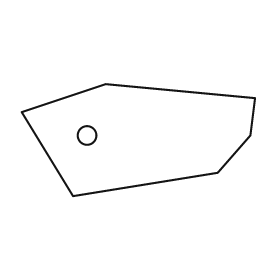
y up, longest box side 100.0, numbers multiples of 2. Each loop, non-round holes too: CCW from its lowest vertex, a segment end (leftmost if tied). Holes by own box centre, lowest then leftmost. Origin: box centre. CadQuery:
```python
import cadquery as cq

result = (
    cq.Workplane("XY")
    .moveTo(-28.0, -24.0)
    .lineTo(34.0, -14.0)
    .lineTo(48.0, 2.0)
    .lineTo(50.0, 18.0)
    .lineTo(-14.0, 24.0)
    .lineTo(-50.0, 12.0)
    .close()
    .moveTo(-22.0, 2.0)
    .circle(4.0)
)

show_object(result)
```